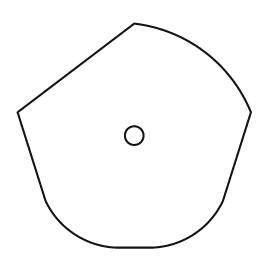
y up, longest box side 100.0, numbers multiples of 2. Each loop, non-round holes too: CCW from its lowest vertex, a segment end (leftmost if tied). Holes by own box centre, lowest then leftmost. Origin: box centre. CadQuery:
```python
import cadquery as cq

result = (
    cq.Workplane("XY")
    .moveTo(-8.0, -48.0)
    .lineTo(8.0, -48.0)
    .threePointArc((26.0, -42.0), (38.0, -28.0))
    .lineTo(50.0, 10.0)
    .threePointArc((30.0, 36.0), (0.0, 48.0))
    .lineTo(-50.0, 10.0)
    .lineTo(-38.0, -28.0)
    .threePointArc((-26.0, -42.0), (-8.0, -48.0))
    .close()
    .moveTo(0.0, 0.0)
    .circle(4.0)
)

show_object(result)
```